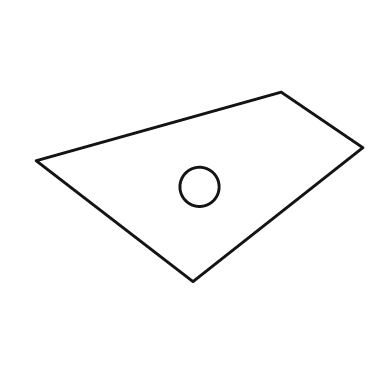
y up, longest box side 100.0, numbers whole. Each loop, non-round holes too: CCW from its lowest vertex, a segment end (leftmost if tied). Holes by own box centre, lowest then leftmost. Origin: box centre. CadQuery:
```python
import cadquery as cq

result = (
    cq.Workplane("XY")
    .moveTo(-2.0, -29.0)
    .lineTo(50.0, 12.0)
    .lineTo(25.0, 29.0)
    .lineTo(-50.0, 8.0)
    .close()
    .moveTo(0.0, 0.0)
    .circle(6.0)
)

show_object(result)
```